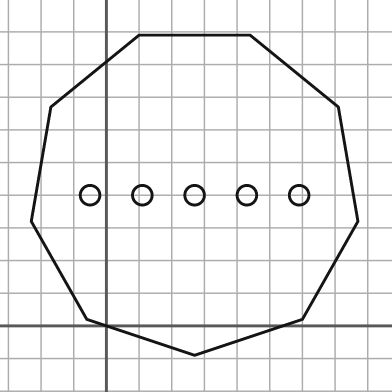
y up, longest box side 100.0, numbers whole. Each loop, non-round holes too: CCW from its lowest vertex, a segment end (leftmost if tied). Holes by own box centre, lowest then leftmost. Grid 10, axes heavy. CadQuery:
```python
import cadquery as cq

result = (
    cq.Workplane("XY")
    .moveTo(27.0, -9.0)
    .lineTo(60.0, 2.0)
    .lineTo(77.0, 32.0)
    .lineTo(71.0, 67.0)
    .lineTo(44.0, 89.0)
    .lineTo(10.0, 89.0)
    .lineTo(-17.0, 67.0)
    .lineTo(-23.0, 32.0)
    .lineTo(-6.0, 2.0)
    .close()
    .moveTo(-5.0, 40.0)
    .circle(3.0)
    .moveTo(11.0, 40.0)
    .circle(3.0)
    .moveTo(27.0, 40.0)
    .circle(3.0)
    .moveTo(43.0, 40.0)
    .circle(3.0)
    .moveTo(59.0, 40.0)
    .circle(3.0)
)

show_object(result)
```